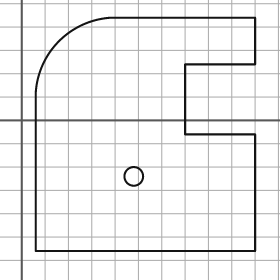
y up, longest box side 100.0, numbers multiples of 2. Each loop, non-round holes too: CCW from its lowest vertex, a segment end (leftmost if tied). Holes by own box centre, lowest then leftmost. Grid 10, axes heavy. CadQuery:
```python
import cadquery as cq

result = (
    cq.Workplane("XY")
    .moveTo(6.0, -56.0)
    .lineTo(100.0, -56.0)
    .lineTo(100.0, -6.0)
    .lineTo(70.0, -6.0)
    .lineTo(70.0, 24.0)
    .lineTo(100.0, 24.0)
    .lineTo(100.0, 44.0)
    .lineTo(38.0, 44.0)
    .threePointArc((16.0, 34.0), (6.0, 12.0))
    .close()
    .moveTo(48.0, -24.0)
    .circle(4.0)
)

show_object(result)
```